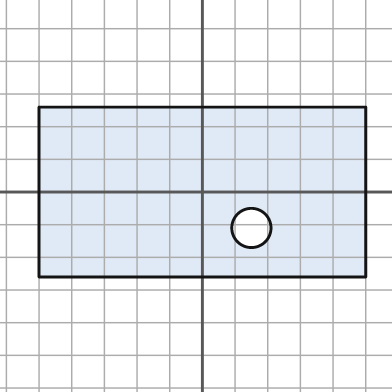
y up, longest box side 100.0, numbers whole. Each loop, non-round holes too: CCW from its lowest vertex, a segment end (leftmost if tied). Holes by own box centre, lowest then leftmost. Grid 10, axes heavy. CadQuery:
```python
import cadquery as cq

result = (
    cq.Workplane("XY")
    .moveTo(-50.0, -26.0)
    .lineTo(50.0, -26.0)
    .lineTo(50.0, 26.0)
    .lineTo(-50.0, 26.0)
    .close()
    .moveTo(15.0, -11.0)
    .circle(6.0)
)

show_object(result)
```